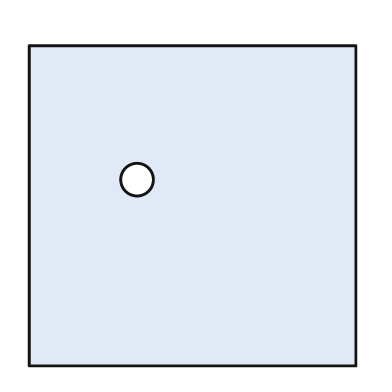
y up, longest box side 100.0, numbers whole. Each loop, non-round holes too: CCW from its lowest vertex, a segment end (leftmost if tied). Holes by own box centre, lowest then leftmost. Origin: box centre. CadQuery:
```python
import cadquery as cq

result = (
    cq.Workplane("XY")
    .moveTo(-50.0, -49.0)
    .lineTo(50.0, -49.0)
    .lineTo(50.0, 49.0)
    .lineTo(-50.0, 49.0)
    .close()
    .moveTo(-17.0, 8.0)
    .circle(5.0)
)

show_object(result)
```